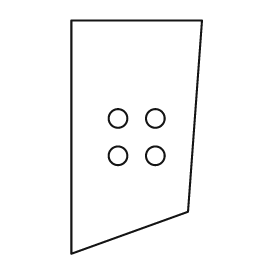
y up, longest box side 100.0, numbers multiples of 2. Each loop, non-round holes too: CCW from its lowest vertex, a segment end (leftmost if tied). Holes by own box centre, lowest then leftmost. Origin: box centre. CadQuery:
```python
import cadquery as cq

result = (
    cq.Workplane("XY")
    .moveTo(-28.0, -50.0)
    .lineTo(22.0, -32.0)
    .lineTo(28.0, 50.0)
    .lineTo(-28.0, 50.0)
    .close()
    .moveTo(-8.0, -8.0)
    .circle(4.0)
    .moveTo(8.0, -8.0)
    .circle(4.0)
    .moveTo(-8.0, 8.0)
    .circle(4.0)
    .moveTo(8.0, 8.0)
    .circle(4.0)
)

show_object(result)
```